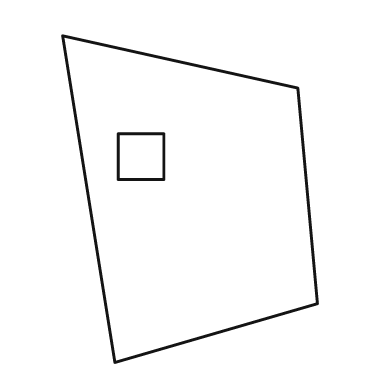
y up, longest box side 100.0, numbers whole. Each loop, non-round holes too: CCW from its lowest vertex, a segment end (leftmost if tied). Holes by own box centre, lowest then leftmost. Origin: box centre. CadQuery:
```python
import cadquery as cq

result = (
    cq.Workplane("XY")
    .moveTo(-23.0, -50.0)
    .lineTo(39.0, -32.0)
    .lineTo(33.0, 34.0)
    .lineTo(-39.0, 50.0)
    .close()
    .moveTo(-22.0, 6.0)
    .lineTo(-8.0, 6.0)
    .lineTo(-8.0, 20.0)
    .lineTo(-22.0, 20.0)
    .close()
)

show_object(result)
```